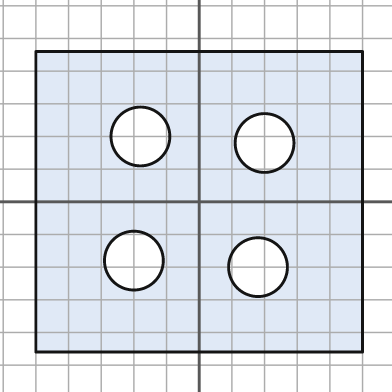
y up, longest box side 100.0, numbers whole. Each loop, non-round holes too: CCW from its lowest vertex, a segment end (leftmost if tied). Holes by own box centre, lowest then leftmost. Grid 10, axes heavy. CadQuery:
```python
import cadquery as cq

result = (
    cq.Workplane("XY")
    .moveTo(-50.0, -46.0)
    .lineTo(50.0, -46.0)
    .lineTo(50.0, 46.0)
    .lineTo(-50.0, 46.0)
    .close()
    .moveTo(18.0, -20.0)
    .circle(9.0)
    .moveTo(-20.0, -18.0)
    .circle(9.0)
    .moveTo(20.0, 18.0)
    .circle(9.0)
    .moveTo(-18.0, 20.0)
    .circle(9.0)
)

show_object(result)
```